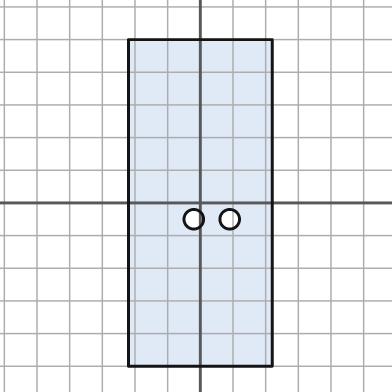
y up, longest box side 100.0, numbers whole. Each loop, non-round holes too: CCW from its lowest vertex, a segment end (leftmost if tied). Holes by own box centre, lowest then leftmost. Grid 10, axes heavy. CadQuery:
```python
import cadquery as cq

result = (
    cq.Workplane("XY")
    .moveTo(-22.0, -50.0)
    .lineTo(22.0, -50.0)
    .lineTo(22.0, 50.0)
    .lineTo(-22.0, 50.0)
    .close()
    .moveTo(-2.0, -5.0)
    .circle(3.0)
    .moveTo(9.0, -5.0)
    .circle(3.0)
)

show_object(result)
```